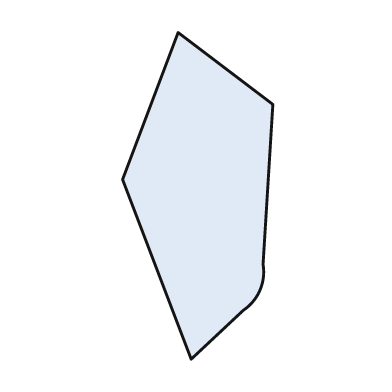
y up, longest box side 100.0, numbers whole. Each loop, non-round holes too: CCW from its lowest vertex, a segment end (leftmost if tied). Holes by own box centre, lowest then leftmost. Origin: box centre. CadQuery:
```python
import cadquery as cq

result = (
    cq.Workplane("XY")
    .moveTo(-2.0, -50.0)
    .lineTo(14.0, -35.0)
    .threePointArc((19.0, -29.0), (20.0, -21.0))
    .lineTo(23.0, 28.0)
    .lineTo(-6.0, 50.0)
    .lineTo(-23.0, 5.0)
    .close()
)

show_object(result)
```